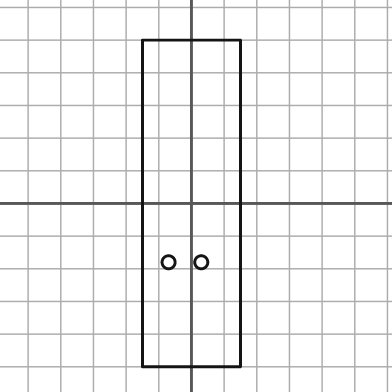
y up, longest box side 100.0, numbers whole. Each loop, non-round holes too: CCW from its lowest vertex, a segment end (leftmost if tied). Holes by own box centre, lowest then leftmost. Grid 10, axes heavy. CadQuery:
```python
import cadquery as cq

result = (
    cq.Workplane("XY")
    .moveTo(-15.0, -50.0)
    .lineTo(15.0, -50.0)
    .lineTo(15.0, 50.0)
    .lineTo(-15.0, 50.0)
    .close()
    .moveTo(-7.0, -18.0)
    .circle(2.0)
    .moveTo(3.0, -18.0)
    .circle(2.0)
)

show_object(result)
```